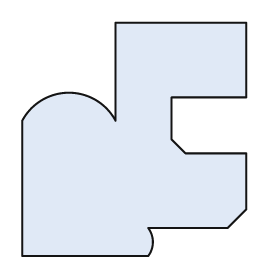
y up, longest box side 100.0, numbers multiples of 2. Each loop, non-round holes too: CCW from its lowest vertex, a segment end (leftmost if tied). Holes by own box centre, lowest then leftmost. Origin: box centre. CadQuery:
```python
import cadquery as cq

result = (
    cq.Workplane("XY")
    .moveTo(-48.0, -50.0)
    .lineTo(6.0, -50.0)
    .threePointArc((8.0, -44.0), (6.0, -38.0))
    .lineTo(40.0, -38.0)
    .lineTo(48.0, -30.0)
    .lineTo(48.0, -6.0)
    .lineTo(22.0, -6.0)
    .lineTo(16.0, 0.0)
    .lineTo(16.0, 18.0)
    .lineTo(48.0, 18.0)
    .lineTo(48.0, 50.0)
    .lineTo(-8.0, 50.0)
    .lineTo(-8.0, 8.0)
    .threePointArc((-28.0, 20.0), (-48.0, 8.0))
    .close()
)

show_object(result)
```